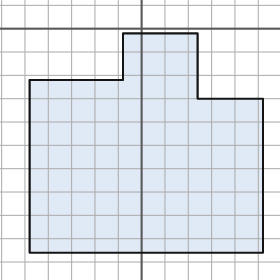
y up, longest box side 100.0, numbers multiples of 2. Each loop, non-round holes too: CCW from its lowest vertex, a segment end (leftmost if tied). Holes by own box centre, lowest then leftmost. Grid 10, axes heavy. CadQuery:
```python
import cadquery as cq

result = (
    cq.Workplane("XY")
    .moveTo(-48.0, -96.0)
    .lineTo(52.0, -96.0)
    .lineTo(52.0, -30.0)
    .lineTo(24.0, -30.0)
    .lineTo(24.0, -2.0)
    .lineTo(-8.0, -2.0)
    .lineTo(-8.0, -22.0)
    .lineTo(-48.0, -22.0)
    .close()
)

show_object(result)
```